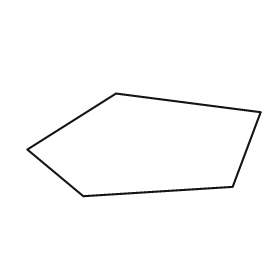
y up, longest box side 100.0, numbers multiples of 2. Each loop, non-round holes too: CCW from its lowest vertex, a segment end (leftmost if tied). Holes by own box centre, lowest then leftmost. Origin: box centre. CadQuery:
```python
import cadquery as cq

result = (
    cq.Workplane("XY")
    .moveTo(-26.0, -22.0)
    .lineTo(38.0, -18.0)
    .lineTo(50.0, 14.0)
    .lineTo(-12.0, 22.0)
    .lineTo(-50.0, -2.0)
    .close()
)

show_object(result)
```